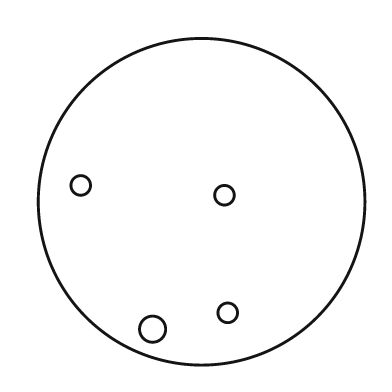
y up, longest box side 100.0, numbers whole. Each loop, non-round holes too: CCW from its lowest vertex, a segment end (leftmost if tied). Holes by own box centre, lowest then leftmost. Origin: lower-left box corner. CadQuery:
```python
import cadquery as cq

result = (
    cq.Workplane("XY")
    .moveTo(50.0, 50.0)
    .circle(50.0)
    .moveTo(35.0, 11.0)
    .circle(4.0)
    .moveTo(58.0, 16.0)
    .circle(3.0)
    .moveTo(57.0, 52.0)
    .circle(3.0)
    .moveTo(13.0, 55.0)
    .circle(3.0)
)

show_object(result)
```